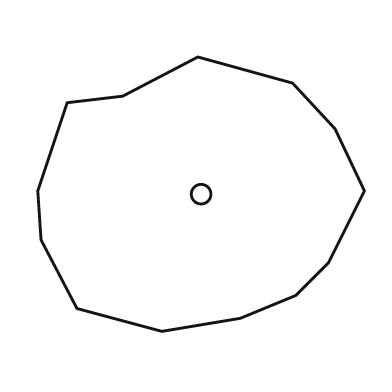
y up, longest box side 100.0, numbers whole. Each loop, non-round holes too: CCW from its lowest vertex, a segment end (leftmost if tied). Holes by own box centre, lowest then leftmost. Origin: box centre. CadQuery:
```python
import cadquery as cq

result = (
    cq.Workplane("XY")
    .moveTo(-12.0, -42.0)
    .lineTo(12.0, -38.0)
    .lineTo(29.0, -31.0)
    .lineTo(39.0, -21.0)
    .lineTo(50.0, 1.0)
    .lineTo(41.0, 20.0)
    .lineTo(28.0, 34.0)
    .lineTo(-1.0, 42.0)
    .lineTo(-24.0, 30.0)
    .lineTo(-41.0, 28.0)
    .lineTo(-50.0, 1.0)
    .lineTo(-49.0, -14.0)
    .lineTo(-38.0, -35.0)
    .close()
    .moveTo(0.0, 0.0)
    .circle(3.0)
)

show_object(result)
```